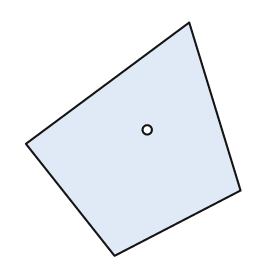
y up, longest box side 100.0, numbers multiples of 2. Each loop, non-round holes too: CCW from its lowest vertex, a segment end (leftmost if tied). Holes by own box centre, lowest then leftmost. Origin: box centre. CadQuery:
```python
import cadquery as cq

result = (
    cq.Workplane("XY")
    .moveTo(-8.0, -50.0)
    .lineTo(46.0, -22.0)
    .lineTo(24.0, 50.0)
    .lineTo(-46.0, -2.0)
    .close()
    .moveTo(6.0, 4.0)
    .circle(2.0)
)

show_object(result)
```